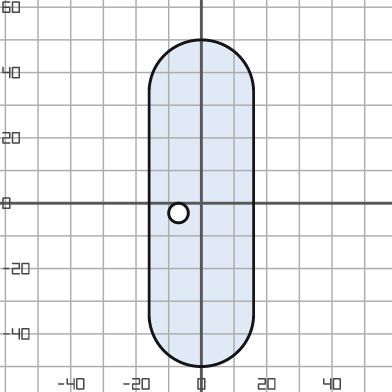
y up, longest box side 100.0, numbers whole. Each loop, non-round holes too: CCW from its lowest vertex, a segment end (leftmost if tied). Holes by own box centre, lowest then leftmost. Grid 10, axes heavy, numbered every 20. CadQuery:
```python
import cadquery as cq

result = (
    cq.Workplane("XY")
    .moveTo(-16.0, -34.0)
    .threePointArc((0.0, -50.0), (16.0, -34.0))
    .lineTo(16.0, 34.0)
    .threePointArc((0.0, 50.0), (-16.0, 34.0))
    .close()
    .moveTo(-7.0, -3.0)
    .circle(3.0)
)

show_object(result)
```